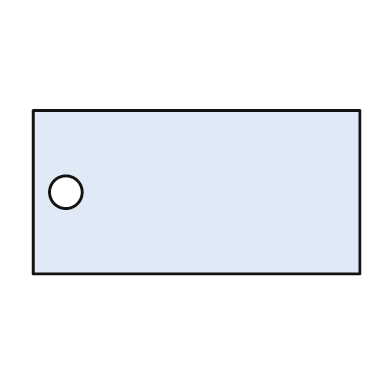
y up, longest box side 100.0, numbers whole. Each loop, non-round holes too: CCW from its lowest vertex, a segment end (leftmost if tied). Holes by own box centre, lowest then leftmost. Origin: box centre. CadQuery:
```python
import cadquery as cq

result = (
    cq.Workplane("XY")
    .moveTo(-50.0, -25.0)
    .lineTo(50.0, -25.0)
    .lineTo(50.0, 25.0)
    .lineTo(-50.0, 25.0)
    .close()
    .moveTo(-40.0, 0.0)
    .circle(5.0)
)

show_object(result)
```